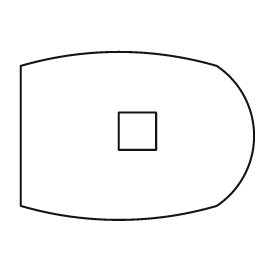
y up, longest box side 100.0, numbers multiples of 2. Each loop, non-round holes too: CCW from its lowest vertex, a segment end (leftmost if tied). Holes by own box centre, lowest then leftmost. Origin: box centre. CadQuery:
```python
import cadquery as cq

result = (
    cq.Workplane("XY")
    .moveTo(-50.0, -30.0)
    .threePointArc((-8.0, -36.0), (34.0, -30.0))
    .threePointArc((50.0, 0.0), (34.0, 30.0))
    .threePointArc((-8.0, 36.0), (-50.0, 30.0))
    .close()
    .moveTo(-8.0, -6.0)
    .lineTo(8.0, -6.0)
    .lineTo(8.0, 10.0)
    .lineTo(-8.0, 10.0)
    .close()
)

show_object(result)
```